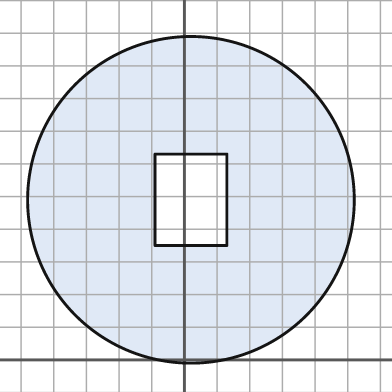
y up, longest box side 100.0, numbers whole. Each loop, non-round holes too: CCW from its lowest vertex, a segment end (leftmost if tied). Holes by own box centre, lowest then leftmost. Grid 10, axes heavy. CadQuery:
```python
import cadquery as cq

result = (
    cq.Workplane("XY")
    .moveTo(2.0, 49.0)
    .circle(50.0)
    .moveTo(-9.0, 35.0)
    .lineTo(13.0, 35.0)
    .lineTo(13.0, 63.0)
    .lineTo(-9.0, 63.0)
    .close()
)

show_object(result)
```